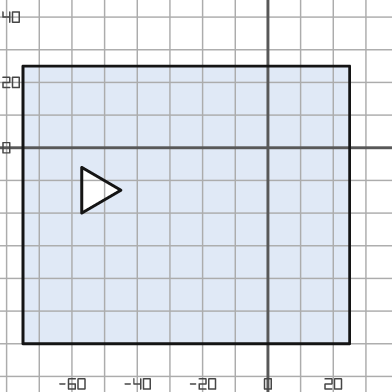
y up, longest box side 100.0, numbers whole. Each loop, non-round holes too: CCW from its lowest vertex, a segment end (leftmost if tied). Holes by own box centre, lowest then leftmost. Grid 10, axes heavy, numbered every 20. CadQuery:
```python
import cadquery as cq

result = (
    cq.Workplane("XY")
    .moveTo(-75.0, -60.0)
    .lineTo(25.0, -60.0)
    .lineTo(25.0, 25.0)
    .lineTo(-75.0, 25.0)
    .close()
    .moveTo(-57.0, -20.0)
    .lineTo(-45.0, -13.0)
    .lineTo(-57.0, -6.0)
    .close()
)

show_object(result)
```